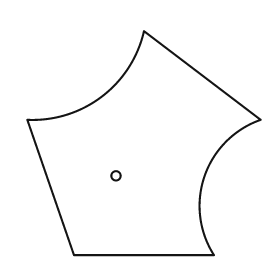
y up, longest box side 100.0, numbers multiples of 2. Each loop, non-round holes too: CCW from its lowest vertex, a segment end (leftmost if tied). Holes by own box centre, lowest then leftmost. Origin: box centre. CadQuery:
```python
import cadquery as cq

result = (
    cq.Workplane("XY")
    .moveTo(-30.0, -48.0)
    .lineTo(30.0, -48.0)
    .threePointArc((26.0, -14.0), (50.0, 10.0))
    .lineTo(0.0, 48.0)
    .threePointArc((-18.0, 20.0), (-50.0, 10.0))
    .close()
    .moveTo(-12.0, -14.0)
    .circle(2.0)
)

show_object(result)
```